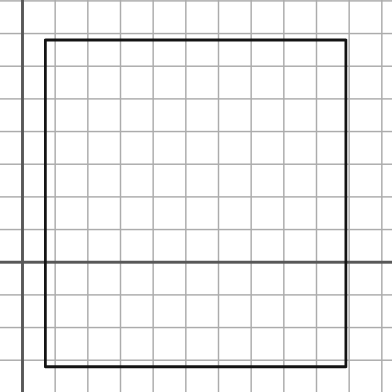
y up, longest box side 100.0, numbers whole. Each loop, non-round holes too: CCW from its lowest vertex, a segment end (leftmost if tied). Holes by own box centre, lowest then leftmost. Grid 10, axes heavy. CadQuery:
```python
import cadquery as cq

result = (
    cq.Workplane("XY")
    .moveTo(7.0, -32.0)
    .lineTo(99.0, -32.0)
    .lineTo(99.0, 68.0)
    .lineTo(7.0, 68.0)
    .close()
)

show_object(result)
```